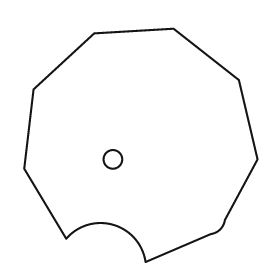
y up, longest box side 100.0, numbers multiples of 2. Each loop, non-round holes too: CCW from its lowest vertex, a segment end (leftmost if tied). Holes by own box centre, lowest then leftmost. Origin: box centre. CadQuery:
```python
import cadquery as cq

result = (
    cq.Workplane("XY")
    .moveTo(2.0, -50.0)
    .lineTo(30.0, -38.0)
    .threePointArc((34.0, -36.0), (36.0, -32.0))
    .lineTo(50.0, -6.0)
    .lineTo(42.0, 28.0)
    .lineTo(14.0, 50.0)
    .lineTo(-20.0, 48.0)
    .lineTo(-46.0, 24.0)
    .lineTo(-50.0, -10.0)
    .lineTo(-32.0, -40.0)
    .threePointArc((-12.0, -34.0), (2.0, -50.0))
    .close()
    .moveTo(-12.0, -6.0)
    .circle(4.0)
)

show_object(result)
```